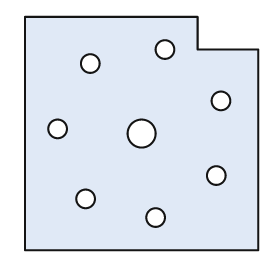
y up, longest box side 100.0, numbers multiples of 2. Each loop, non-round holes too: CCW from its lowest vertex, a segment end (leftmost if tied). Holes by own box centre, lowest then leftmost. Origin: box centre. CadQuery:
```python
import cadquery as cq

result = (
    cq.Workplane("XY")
    .moveTo(-50.0, -50.0)
    .lineTo(50.0, -50.0)
    .lineTo(50.0, 36.0)
    .lineTo(24.0, 36.0)
    .lineTo(24.0, 50.0)
    .lineTo(-50.0, 50.0)
    .close()
    .moveTo(6.0, -36.0)
    .circle(4.0)
    .moveTo(-24.0, -28.0)
    .circle(4.0)
    .moveTo(32.0, -18.0)
    .circle(4.0)
    .moveTo(0.0, 0.0)
    .circle(6.0)
    .moveTo(-36.0, 2.0)
    .circle(4.0)
    .moveTo(34.0, 14.0)
    .circle(4.0)
    .moveTo(-22.0, 30.0)
    .circle(4.0)
    .moveTo(10.0, 36.0)
    .circle(4.0)
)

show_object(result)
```